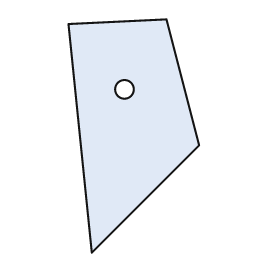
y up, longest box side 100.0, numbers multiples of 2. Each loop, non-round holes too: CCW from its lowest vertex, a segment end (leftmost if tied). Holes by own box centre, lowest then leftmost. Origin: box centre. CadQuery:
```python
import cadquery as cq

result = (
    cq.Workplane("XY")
    .moveTo(-18.0, -50.0)
    .lineTo(28.0, -4.0)
    .lineTo(14.0, 50.0)
    .lineTo(-28.0, 48.0)
    .close()
    .moveTo(-4.0, 20.0)
    .circle(4.0)
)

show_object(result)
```